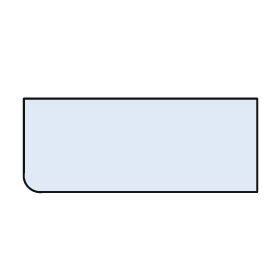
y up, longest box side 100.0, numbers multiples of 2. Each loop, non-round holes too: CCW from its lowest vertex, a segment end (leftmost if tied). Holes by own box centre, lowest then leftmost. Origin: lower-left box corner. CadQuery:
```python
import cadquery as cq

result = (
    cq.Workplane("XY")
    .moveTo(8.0, 0.0)
    .lineTo(100.0, 0.0)
    .lineTo(100.0, 40.0)
    .lineTo(0.0, 40.0)
    .lineTo(0.0, 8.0)
    .threePointArc((2.0, 2.0), (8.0, 0.0))
    .close()
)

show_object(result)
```